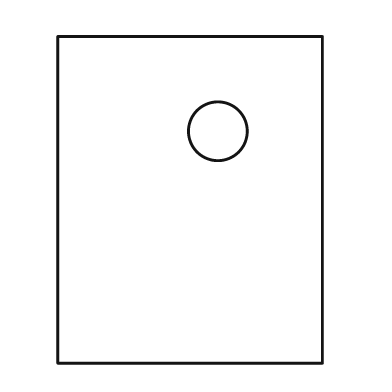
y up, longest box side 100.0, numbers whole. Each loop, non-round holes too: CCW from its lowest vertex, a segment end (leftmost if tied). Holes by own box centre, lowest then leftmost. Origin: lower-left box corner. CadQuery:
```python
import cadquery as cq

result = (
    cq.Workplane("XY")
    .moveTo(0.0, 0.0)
    .lineTo(81.0, 0.0)
    .lineTo(81.0, 100.0)
    .lineTo(0.0, 100.0)
    .close()
    .moveTo(49.0, 71.0)
    .circle(9.0)
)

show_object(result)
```